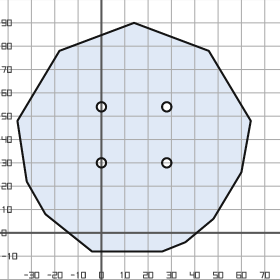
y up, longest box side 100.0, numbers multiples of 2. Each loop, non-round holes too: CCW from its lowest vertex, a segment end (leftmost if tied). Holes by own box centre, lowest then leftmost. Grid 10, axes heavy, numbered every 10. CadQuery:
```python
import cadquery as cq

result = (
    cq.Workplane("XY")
    .moveTo(-4.0, -8.0)
    .lineTo(26.0, -8.0)
    .lineTo(36.0, -4.0)
    .lineTo(48.0, 6.0)
    .lineTo(60.0, 26.0)
    .lineTo(64.0, 48.0)
    .lineTo(46.0, 78.0)
    .lineTo(14.0, 90.0)
    .lineTo(-18.0, 78.0)
    .lineTo(-36.0, 48.0)
    .lineTo(-32.0, 22.0)
    .lineTo(-24.0, 8.0)
    .close()
    .moveTo(0.0, 30.0)
    .circle(2.0)
    .moveTo(28.0, 30.0)
    .circle(2.0)
    .moveTo(0.0, 54.0)
    .circle(2.0)
    .moveTo(28.0, 54.0)
    .circle(2.0)
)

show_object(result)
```